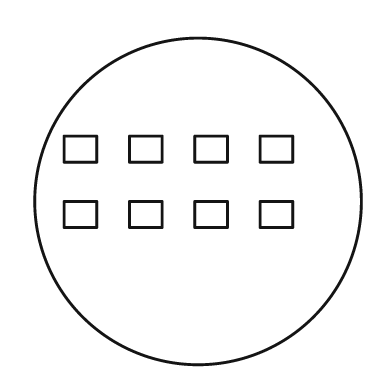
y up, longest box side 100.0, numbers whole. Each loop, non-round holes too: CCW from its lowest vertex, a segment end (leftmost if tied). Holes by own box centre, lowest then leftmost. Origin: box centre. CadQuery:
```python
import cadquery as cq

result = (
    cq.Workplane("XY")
    .moveTo(0.0, 0.0)
    .circle(50.0)
    .moveTo(-41.0, -8.0)
    .lineTo(-31.0, -8.0)
    .lineTo(-31.0, 0.0)
    .lineTo(-41.0, 0.0)
    .close()
    .moveTo(-21.0, -8.0)
    .lineTo(-11.0, -8.0)
    .lineTo(-11.0, 0.0)
    .lineTo(-21.0, 0.0)
    .close()
    .moveTo(-1.0, -8.0)
    .lineTo(9.0, -8.0)
    .lineTo(9.0, 0.0)
    .lineTo(-1.0, 0.0)
    .close()
    .moveTo(19.0, -8.0)
    .lineTo(29.0, -8.0)
    .lineTo(29.0, 0.0)
    .lineTo(19.0, 0.0)
    .close()
    .moveTo(-41.0, 12.0)
    .lineTo(-31.0, 12.0)
    .lineTo(-31.0, 20.0)
    .lineTo(-41.0, 20.0)
    .close()
    .moveTo(-21.0, 12.0)
    .lineTo(-11.0, 12.0)
    .lineTo(-11.0, 20.0)
    .lineTo(-21.0, 20.0)
    .close()
    .moveTo(-1.0, 12.0)
    .lineTo(9.0, 12.0)
    .lineTo(9.0, 20.0)
    .lineTo(-1.0, 20.0)
    .close()
    .moveTo(19.0, 12.0)
    .lineTo(29.0, 12.0)
    .lineTo(29.0, 20.0)
    .lineTo(19.0, 20.0)
    .close()
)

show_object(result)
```